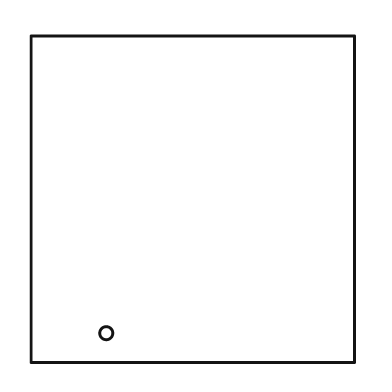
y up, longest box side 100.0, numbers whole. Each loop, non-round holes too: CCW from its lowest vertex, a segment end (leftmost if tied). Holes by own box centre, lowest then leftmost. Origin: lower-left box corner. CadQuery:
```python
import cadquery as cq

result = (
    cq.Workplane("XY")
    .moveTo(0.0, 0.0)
    .lineTo(99.0, 0.0)
    .lineTo(99.0, 100.0)
    .lineTo(0.0, 100.0)
    .close()
    .moveTo(23.0, 9.0)
    .circle(2.0)
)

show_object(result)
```